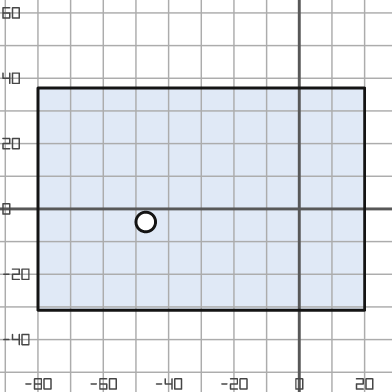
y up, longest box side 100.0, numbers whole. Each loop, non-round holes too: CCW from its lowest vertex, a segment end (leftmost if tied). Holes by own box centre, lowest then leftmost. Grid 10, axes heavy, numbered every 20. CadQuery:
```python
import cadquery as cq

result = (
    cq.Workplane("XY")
    .moveTo(-80.0, -31.0)
    .lineTo(20.0, -31.0)
    .lineTo(20.0, 37.0)
    .lineTo(-80.0, 37.0)
    .close()
    .moveTo(-47.0, -4.0)
    .circle(3.0)
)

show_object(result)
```